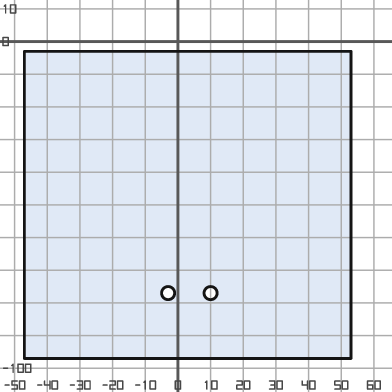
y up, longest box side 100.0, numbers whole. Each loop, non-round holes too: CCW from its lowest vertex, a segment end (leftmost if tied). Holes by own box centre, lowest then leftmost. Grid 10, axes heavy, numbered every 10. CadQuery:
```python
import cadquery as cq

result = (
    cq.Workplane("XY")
    .moveTo(-47.0, -97.0)
    .lineTo(53.0, -97.0)
    .lineTo(53.0, -3.0)
    .lineTo(-47.0, -3.0)
    .close()
    .moveTo(-3.0, -77.0)
    .circle(2.0)
    .moveTo(10.0, -77.0)
    .circle(2.0)
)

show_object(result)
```